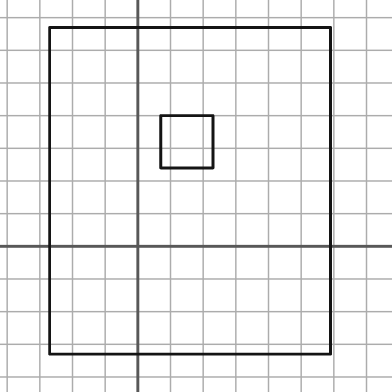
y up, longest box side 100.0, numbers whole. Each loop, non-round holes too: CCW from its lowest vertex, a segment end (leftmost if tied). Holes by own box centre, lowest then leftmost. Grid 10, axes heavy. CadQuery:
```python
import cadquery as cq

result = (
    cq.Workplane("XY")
    .moveTo(-27.0, -33.0)
    .lineTo(59.0, -33.0)
    .lineTo(59.0, 67.0)
    .lineTo(-27.0, 67.0)
    .close()
    .moveTo(7.0, 24.0)
    .lineTo(23.0, 24.0)
    .lineTo(23.0, 40.0)
    .lineTo(7.0, 40.0)
    .close()
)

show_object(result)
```